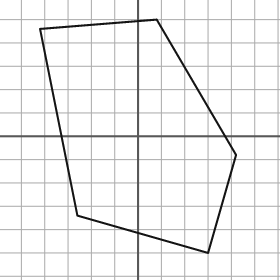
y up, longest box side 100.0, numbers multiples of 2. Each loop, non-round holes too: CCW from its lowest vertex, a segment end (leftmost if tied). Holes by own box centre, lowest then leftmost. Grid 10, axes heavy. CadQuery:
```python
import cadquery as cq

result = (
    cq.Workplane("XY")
    .moveTo(30.0, -50.0)
    .lineTo(42.0, -8.0)
    .lineTo(8.0, 50.0)
    .lineTo(-42.0, 46.0)
    .lineTo(-26.0, -34.0)
    .close()
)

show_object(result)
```